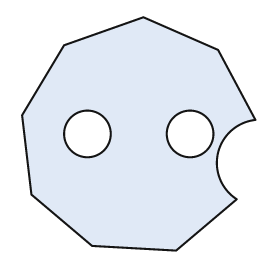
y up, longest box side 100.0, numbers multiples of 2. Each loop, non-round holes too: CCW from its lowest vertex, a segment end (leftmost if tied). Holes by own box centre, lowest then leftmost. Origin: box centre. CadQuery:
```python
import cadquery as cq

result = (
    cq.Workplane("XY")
    .moveTo(16.0, -50.0)
    .lineTo(42.0, -28.0)
    .threePointArc((34.0, -8.0), (50.0, 6.0))
    .lineTo(34.0, 36.0)
    .lineTo(2.0, 50.0)
    .lineTo(-32.0, 38.0)
    .lineTo(-50.0, 8.0)
    .lineTo(-46.0, -26.0)
    .lineTo(-20.0, -48.0)
    .close()
    .moveTo(-22.0, 0.0)
    .circle(10.0)
    .moveTo(22.0, 0.0)
    .circle(10.0)
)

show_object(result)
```